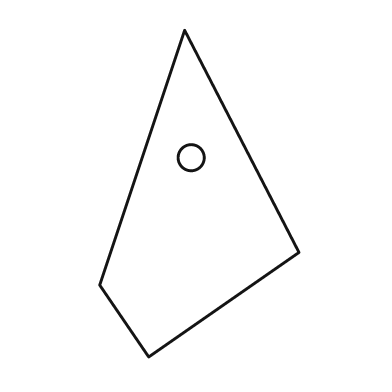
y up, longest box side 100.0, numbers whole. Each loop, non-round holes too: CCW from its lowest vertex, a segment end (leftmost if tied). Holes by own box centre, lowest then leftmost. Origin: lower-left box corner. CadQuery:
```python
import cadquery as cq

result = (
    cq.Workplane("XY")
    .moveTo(15.0, 0.0)
    .lineTo(61.0, 32.0)
    .lineTo(26.0, 100.0)
    .lineTo(0.0, 22.0)
    .close()
    .moveTo(28.0, 61.0)
    .circle(4.0)
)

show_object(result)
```